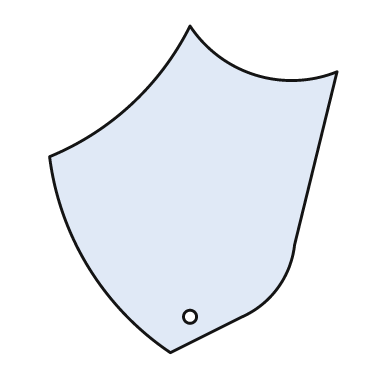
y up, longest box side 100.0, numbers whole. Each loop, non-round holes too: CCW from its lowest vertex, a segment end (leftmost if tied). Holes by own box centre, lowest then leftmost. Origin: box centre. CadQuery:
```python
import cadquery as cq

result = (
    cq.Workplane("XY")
    .moveTo(-7.0, -50.0)
    .lineTo(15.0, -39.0)
    .threePointArc((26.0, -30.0), (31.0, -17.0))
    .lineTo(44.0, 36.0)
    .threePointArc((19.0, 35.0), (-1.0, 50.0))
    .threePointArc((-19.0, 26.0), (-44.0, 10.0))
    .threePointArc((-32.0, -24.0), (-7.0, -50.0))
    .close()
    .moveTo(-1.0, -39.0)
    .circle(2.0)
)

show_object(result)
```